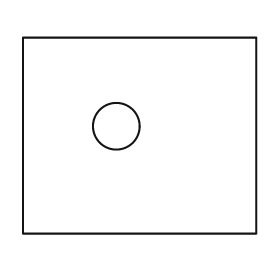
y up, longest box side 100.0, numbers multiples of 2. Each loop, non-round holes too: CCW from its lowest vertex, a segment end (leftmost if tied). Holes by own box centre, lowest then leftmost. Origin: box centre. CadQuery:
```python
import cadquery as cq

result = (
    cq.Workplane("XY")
    .moveTo(-50.0, -42.0)
    .lineTo(50.0, -42.0)
    .lineTo(50.0, 42.0)
    .lineTo(-50.0, 42.0)
    .close()
    .moveTo(-10.0, 4.0)
    .circle(10.0)
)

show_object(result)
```